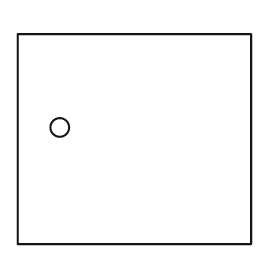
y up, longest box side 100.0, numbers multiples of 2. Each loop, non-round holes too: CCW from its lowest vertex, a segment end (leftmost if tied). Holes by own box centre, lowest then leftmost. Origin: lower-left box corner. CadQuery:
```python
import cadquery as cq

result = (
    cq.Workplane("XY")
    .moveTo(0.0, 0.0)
    .lineTo(100.0, 0.0)
    .lineTo(100.0, 90.0)
    .lineTo(0.0, 90.0)
    .close()
    .moveTo(18.0, 50.0)
    .circle(4.0)
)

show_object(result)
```